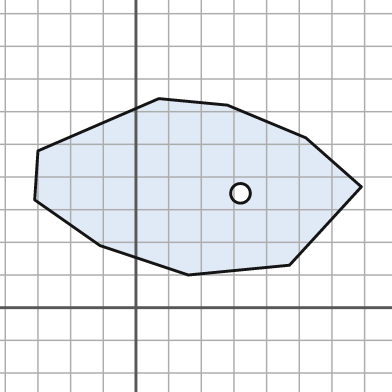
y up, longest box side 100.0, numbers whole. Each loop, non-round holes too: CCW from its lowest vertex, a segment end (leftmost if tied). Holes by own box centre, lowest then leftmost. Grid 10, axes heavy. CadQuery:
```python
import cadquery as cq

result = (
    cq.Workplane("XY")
    .moveTo(16.0, 10.0)
    .lineTo(47.0, 13.0)
    .lineTo(69.0, 37.0)
    .lineTo(52.0, 52.0)
    .lineTo(28.0, 62.0)
    .lineTo(7.0, 64.0)
    .lineTo(-30.0, 48.0)
    .lineTo(-31.0, 33.0)
    .lineTo(-11.0, 19.0)
    .close()
    .moveTo(32.0, 35.0)
    .circle(3.0)
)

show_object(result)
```